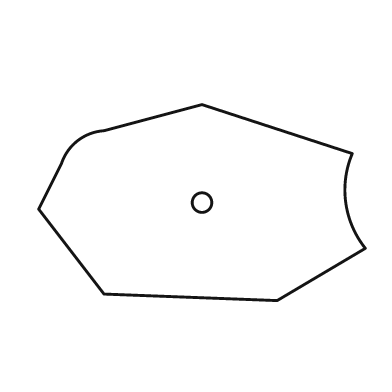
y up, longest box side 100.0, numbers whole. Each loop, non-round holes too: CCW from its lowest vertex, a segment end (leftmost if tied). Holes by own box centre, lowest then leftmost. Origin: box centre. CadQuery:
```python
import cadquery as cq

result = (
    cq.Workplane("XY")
    .moveTo(23.0, -30.0)
    .lineTo(50.0, -14.0)
    .threePointArc((44.0, 0.0), (46.0, 15.0))
    .lineTo(0.0, 30.0)
    .lineTo(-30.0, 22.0)
    .threePointArc((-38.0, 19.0), (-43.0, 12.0))
    .lineTo(-50.0, -2.0)
    .lineTo(-30.0, -28.0)
    .close()
    .moveTo(0.0, 0.0)
    .circle(3.0)
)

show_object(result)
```